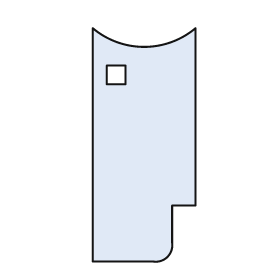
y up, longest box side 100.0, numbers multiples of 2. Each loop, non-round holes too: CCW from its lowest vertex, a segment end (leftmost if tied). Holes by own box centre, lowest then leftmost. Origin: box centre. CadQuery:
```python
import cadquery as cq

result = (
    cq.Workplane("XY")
    .moveTo(-22.0, -50.0)
    .lineTo(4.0, -50.0)
    .threePointArc((10.0, -48.0), (12.0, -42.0))
    .lineTo(12.0, -26.0)
    .lineTo(22.0, -26.0)
    .lineTo(22.0, 50.0)
    .threePointArc((0.0, 42.0), (-22.0, 50.0))
    .close()
    .moveTo(-16.0, 26.0)
    .lineTo(-8.0, 26.0)
    .lineTo(-8.0, 34.0)
    .lineTo(-16.0, 34.0)
    .close()
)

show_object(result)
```